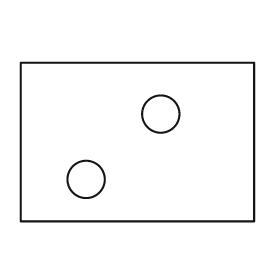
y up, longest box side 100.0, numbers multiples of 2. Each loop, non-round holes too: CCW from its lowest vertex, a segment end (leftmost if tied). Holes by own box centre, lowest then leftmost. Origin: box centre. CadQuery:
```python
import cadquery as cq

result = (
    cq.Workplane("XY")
    .moveTo(-50.0, -34.0)
    .lineTo(50.0, -34.0)
    .lineTo(50.0, 34.0)
    .lineTo(-50.0, 34.0)
    .close()
    .moveTo(-22.0, -16.0)
    .circle(8.0)
    .moveTo(10.0, 12.0)
    .circle(8.0)
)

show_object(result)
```